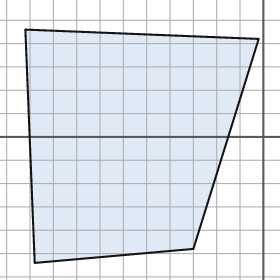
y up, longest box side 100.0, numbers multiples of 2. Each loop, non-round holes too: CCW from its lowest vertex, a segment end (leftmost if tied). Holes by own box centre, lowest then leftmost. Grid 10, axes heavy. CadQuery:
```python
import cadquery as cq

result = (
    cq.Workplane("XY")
    .moveTo(-98.0, -54.0)
    .lineTo(-30.0, -48.0)
    .lineTo(-2.0, 42.0)
    .lineTo(-102.0, 46.0)
    .close()
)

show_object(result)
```